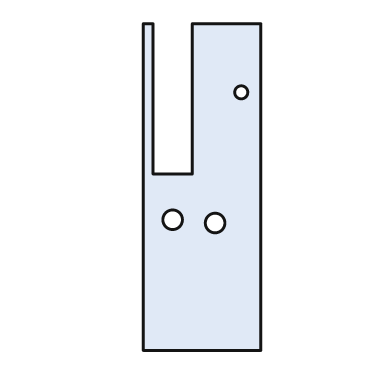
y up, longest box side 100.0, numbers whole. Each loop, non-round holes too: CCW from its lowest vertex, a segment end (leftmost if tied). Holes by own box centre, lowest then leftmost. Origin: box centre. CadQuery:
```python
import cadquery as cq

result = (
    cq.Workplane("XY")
    .moveTo(-18.0, -50.0)
    .lineTo(18.0, -50.0)
    .lineTo(18.0, 50.0)
    .lineTo(-3.0, 50.0)
    .lineTo(-3.0, 4.0)
    .lineTo(-15.0, 4.0)
    .lineTo(-15.0, 50.0)
    .lineTo(-18.0, 50.0)
    .close()
    .moveTo(4.0, -11.0)
    .circle(3.0)
    .moveTo(-9.0, -10.0)
    .circle(3.0)
    .moveTo(12.0, 29.0)
    .circle(2.0)
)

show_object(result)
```